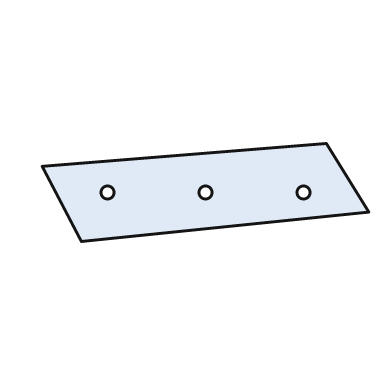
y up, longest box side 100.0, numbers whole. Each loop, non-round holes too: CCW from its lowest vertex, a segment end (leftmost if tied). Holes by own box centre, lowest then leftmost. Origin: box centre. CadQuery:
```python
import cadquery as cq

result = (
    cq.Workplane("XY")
    .moveTo(-38.0, -15.0)
    .lineTo(50.0, -6.0)
    .lineTo(37.0, 15.0)
    .lineTo(-50.0, 8.0)
    .close()
    .moveTo(-30.0, 0.0)
    .circle(2.0)
    .moveTo(0.0, 0.0)
    .circle(2.0)
    .moveTo(30.0, 0.0)
    .circle(2.0)
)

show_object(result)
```